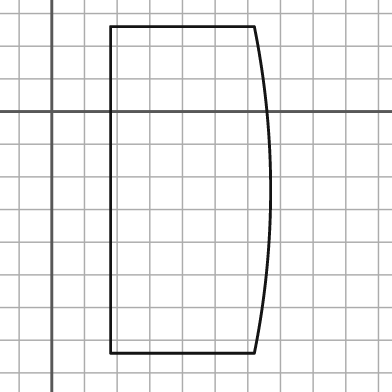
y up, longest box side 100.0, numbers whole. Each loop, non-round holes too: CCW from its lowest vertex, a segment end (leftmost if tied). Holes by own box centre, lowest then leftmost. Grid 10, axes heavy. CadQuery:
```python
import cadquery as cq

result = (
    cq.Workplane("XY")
    .moveTo(18.0, -74.0)
    .lineTo(62.0, -74.0)
    .threePointArc((67.0, -24.0), (62.0, 26.0))
    .lineTo(18.0, 26.0)
    .close()
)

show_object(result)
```